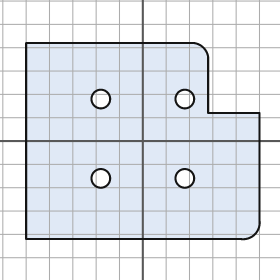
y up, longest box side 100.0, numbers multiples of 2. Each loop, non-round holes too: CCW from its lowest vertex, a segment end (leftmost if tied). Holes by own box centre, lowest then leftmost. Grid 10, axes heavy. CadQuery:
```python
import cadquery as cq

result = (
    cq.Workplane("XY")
    .moveTo(-50.0, -42.0)
    .lineTo(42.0, -42.0)
    .threePointArc((48.0, -40.0), (50.0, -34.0))
    .lineTo(50.0, 12.0)
    .lineTo(28.0, 12.0)
    .lineTo(28.0, 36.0)
    .threePointArc((26.0, 40.0), (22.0, 42.0))
    .lineTo(-50.0, 42.0)
    .close()
    .moveTo(-18.0, -16.0)
    .circle(4.0)
    .moveTo(18.0, -16.0)
    .circle(4.0)
    .moveTo(-18.0, 18.0)
    .circle(4.0)
    .moveTo(18.0, 18.0)
    .circle(4.0)
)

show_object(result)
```